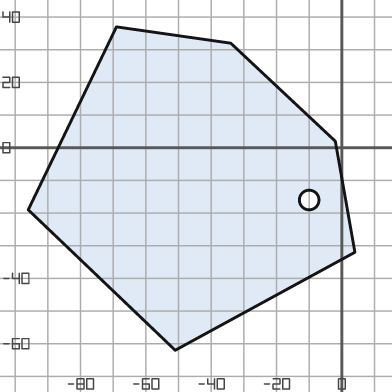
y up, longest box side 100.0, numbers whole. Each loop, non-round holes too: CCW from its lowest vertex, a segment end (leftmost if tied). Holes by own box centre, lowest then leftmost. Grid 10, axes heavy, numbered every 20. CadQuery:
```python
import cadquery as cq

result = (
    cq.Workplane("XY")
    .moveTo(-51.0, -62.0)
    .lineTo(4.0, -32.0)
    .lineTo(-2.0, 2.0)
    .lineTo(-34.0, 32.0)
    .lineTo(-69.0, 37.0)
    .lineTo(-96.0, -19.0)
    .close()
    .moveTo(-10.0, -16.0)
    .circle(3.0)
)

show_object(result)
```